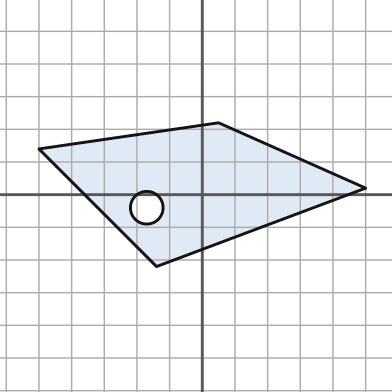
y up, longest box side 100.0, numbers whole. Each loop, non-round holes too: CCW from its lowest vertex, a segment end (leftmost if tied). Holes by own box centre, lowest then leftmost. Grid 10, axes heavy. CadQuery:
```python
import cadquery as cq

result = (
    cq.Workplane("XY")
    .moveTo(-14.0, -22.0)
    .lineTo(50.0, 2.0)
    .lineTo(5.0, 22.0)
    .lineTo(-50.0, 14.0)
    .close()
    .moveTo(-17.0, -4.0)
    .circle(5.0)
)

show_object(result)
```